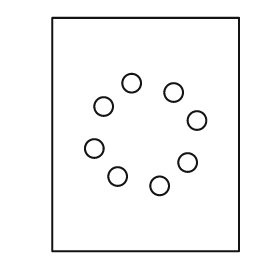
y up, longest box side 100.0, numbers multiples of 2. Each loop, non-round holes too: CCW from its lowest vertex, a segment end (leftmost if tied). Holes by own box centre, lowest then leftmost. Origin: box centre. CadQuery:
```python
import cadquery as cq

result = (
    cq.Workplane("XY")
    .moveTo(-40.0, -50.0)
    .lineTo(40.0, -50.0)
    .lineTo(40.0, 50.0)
    .lineTo(-40.0, 50.0)
    .close()
    .moveTo(6.0, -22.0)
    .circle(4.0)
    .moveTo(-12.0, -18.0)
    .circle(4.0)
    .moveTo(18.0, -12.0)
    .circle(4.0)
    .moveTo(-22.0, -6.0)
    .circle(4.0)
    .moveTo(22.0, 6.0)
    .circle(4.0)
    .moveTo(-18.0, 12.0)
    .circle(4.0)
    .moveTo(12.0, 18.0)
    .circle(4.0)
    .moveTo(-6.0, 22.0)
    .circle(4.0)
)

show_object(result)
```